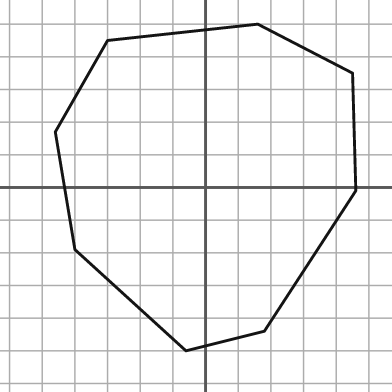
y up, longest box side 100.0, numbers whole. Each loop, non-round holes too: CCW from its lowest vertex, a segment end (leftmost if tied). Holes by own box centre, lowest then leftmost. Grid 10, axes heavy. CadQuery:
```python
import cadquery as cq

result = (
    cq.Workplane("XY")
    .moveTo(-6.0, -50.0)
    .lineTo(18.0, -44.0)
    .lineTo(46.0, -1.0)
    .lineTo(45.0, 35.0)
    .lineTo(16.0, 50.0)
    .lineTo(-30.0, 45.0)
    .lineTo(-46.0, 17.0)
    .lineTo(-40.0, -19.0)
    .close()
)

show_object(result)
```